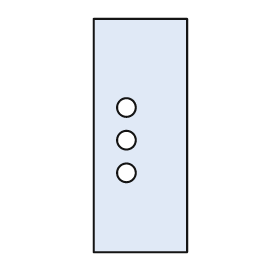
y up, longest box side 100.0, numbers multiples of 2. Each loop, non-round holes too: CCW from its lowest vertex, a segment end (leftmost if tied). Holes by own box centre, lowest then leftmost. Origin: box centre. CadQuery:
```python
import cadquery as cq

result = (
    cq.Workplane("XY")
    .moveTo(-20.0, -50.0)
    .lineTo(20.0, -50.0)
    .lineTo(20.0, 50.0)
    .lineTo(-20.0, 50.0)
    .close()
    .moveTo(-6.0, -16.0)
    .circle(4.0)
    .moveTo(-6.0, -2.0)
    .circle(4.0)
    .moveTo(-6.0, 12.0)
    .circle(4.0)
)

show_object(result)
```